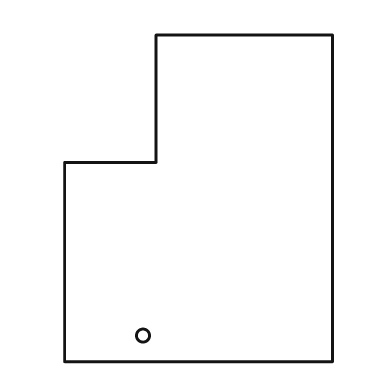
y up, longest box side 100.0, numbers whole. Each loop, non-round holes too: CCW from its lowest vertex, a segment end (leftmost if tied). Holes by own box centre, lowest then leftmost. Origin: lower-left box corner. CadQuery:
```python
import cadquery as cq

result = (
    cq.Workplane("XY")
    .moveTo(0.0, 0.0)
    .lineTo(82.0, 0.0)
    .lineTo(82.0, 100.0)
    .lineTo(28.0, 100.0)
    .lineTo(28.0, 61.0)
    .lineTo(0.0, 61.0)
    .close()
    .moveTo(24.0, 8.0)
    .circle(2.0)
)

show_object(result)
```